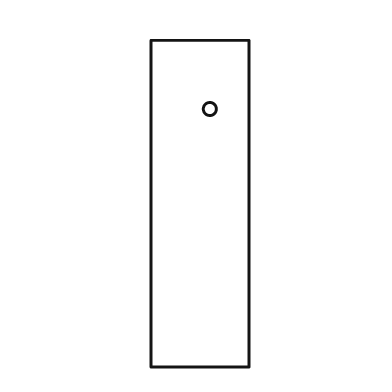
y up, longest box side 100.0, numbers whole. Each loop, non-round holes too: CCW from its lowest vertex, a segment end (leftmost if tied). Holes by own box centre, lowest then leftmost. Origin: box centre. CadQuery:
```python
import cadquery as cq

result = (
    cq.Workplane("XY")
    .moveTo(-15.0, -50.0)
    .lineTo(15.0, -50.0)
    .lineTo(15.0, 50.0)
    .lineTo(-15.0, 50.0)
    .close()
    .moveTo(3.0, 29.0)
    .circle(2.0)
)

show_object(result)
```